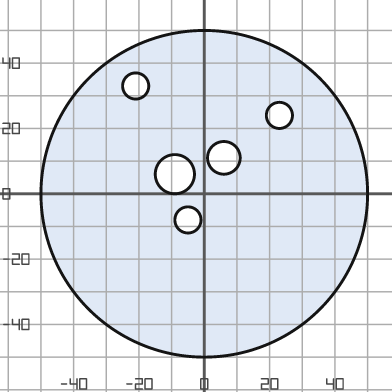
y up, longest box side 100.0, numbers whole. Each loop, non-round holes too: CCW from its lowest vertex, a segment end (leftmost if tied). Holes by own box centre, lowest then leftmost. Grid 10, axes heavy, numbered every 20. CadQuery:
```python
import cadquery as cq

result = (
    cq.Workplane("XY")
    .moveTo(0.0, 0.0)
    .circle(50.0)
    .moveTo(-5.0, -8.0)
    .circle(4.0)
    .moveTo(-9.0, 6.0)
    .circle(6.0)
    .moveTo(6.0, 11.0)
    .circle(5.0)
    .moveTo(23.0, 24.0)
    .circle(4.0)
    .moveTo(-21.0, 33.0)
    .circle(4.0)
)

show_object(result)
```